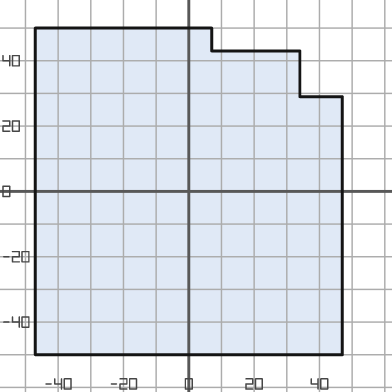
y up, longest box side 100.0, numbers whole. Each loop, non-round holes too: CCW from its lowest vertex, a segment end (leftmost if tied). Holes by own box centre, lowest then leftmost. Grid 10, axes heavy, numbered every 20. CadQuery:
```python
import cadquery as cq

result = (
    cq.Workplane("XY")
    .moveTo(-47.0, -50.0)
    .lineTo(47.0, -50.0)
    .lineTo(47.0, 29.0)
    .lineTo(34.0, 29.0)
    .lineTo(34.0, 43.0)
    .lineTo(7.0, 43.0)
    .lineTo(7.0, 50.0)
    .lineTo(-47.0, 50.0)
    .close()
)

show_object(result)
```